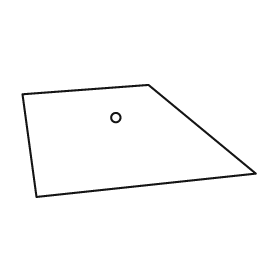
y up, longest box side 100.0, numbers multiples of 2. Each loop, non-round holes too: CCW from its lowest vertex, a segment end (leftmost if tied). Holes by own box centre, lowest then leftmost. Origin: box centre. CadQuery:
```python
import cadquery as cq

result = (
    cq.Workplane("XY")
    .moveTo(-44.0, -24.0)
    .lineTo(50.0, -14.0)
    .lineTo(4.0, 24.0)
    .lineTo(-50.0, 20.0)
    .close()
    .moveTo(-10.0, 10.0)
    .circle(2.0)
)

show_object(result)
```